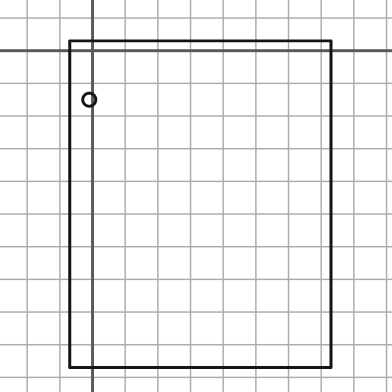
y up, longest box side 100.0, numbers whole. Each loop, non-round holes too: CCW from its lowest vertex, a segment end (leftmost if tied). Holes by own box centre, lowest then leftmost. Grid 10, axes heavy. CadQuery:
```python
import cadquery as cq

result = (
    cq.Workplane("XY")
    .moveTo(-7.0, -97.0)
    .lineTo(73.0, -97.0)
    .lineTo(73.0, 3.0)
    .lineTo(-7.0, 3.0)
    .close()
    .moveTo(-1.0, -15.0)
    .circle(2.0)
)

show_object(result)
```